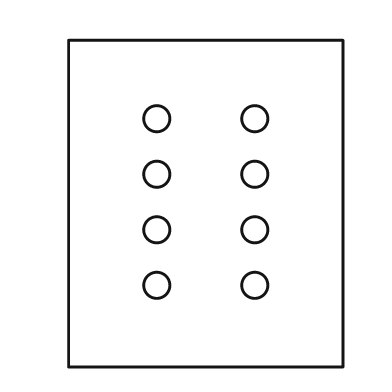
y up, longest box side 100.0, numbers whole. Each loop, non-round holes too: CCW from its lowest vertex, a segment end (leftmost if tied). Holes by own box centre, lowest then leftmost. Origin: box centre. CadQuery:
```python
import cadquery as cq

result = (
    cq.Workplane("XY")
    .moveTo(-42.0, -50.0)
    .lineTo(42.0, -50.0)
    .lineTo(42.0, 50.0)
    .lineTo(-42.0, 50.0)
    .close()
    .moveTo(-15.0, -25.0)
    .circle(4.0)
    .moveTo(15.0, -25.0)
    .circle(4.0)
    .moveTo(-15.0, -8.0)
    .circle(4.0)
    .moveTo(15.0, -8.0)
    .circle(4.0)
    .moveTo(-15.0, 9.0)
    .circle(4.0)
    .moveTo(15.0, 9.0)
    .circle(4.0)
    .moveTo(-15.0, 26.0)
    .circle(4.0)
    .moveTo(15.0, 26.0)
    .circle(4.0)
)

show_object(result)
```